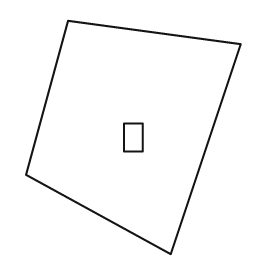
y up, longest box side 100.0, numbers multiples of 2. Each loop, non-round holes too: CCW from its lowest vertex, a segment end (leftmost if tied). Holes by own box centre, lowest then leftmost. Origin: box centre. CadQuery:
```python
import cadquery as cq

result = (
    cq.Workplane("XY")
    .moveTo(16.0, -50.0)
    .lineTo(46.0, 40.0)
    .lineTo(-28.0, 50.0)
    .lineTo(-46.0, -16.0)
    .close()
    .moveTo(-4.0, -6.0)
    .lineTo(4.0, -6.0)
    .lineTo(4.0, 6.0)
    .lineTo(-4.0, 6.0)
    .close()
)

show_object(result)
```